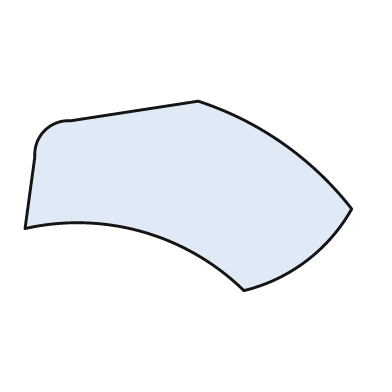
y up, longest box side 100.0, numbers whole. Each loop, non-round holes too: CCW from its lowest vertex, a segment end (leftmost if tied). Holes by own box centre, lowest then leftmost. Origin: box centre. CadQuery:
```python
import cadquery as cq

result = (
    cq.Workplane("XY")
    .moveTo(17.0, -29.0)
    .threePointArc((36.0, -20.0), (50.0, -4.0))
    .threePointArc((29.0, 16.0), (3.0, 29.0))
    .lineTo(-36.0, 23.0)
    .threePointArc((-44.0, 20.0), (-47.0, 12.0))
    .lineTo(-50.0, -10.0)
    .threePointArc((-14.0, -11.0), (17.0, -29.0))
    .close()
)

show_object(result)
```